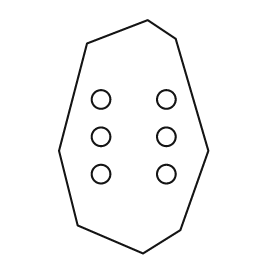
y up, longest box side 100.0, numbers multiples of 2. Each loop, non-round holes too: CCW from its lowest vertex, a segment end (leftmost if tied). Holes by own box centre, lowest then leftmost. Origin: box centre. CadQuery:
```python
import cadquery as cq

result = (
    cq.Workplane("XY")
    .moveTo(4.0, -50.0)
    .lineTo(20.0, -40.0)
    .lineTo(32.0, -6.0)
    .lineTo(18.0, 42.0)
    .lineTo(6.0, 50.0)
    .lineTo(-20.0, 40.0)
    .lineTo(-32.0, -6.0)
    .lineTo(-24.0, -38.0)
    .close()
    .moveTo(-14.0, -16.0)
    .circle(4.0)
    .moveTo(14.0, -16.0)
    .circle(4.0)
    .moveTo(-14.0, 0.0)
    .circle(4.0)
    .moveTo(14.0, 0.0)
    .circle(4.0)
    .moveTo(-14.0, 16.0)
    .circle(4.0)
    .moveTo(14.0, 16.0)
    .circle(4.0)
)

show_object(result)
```